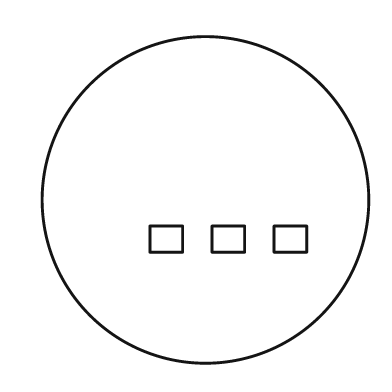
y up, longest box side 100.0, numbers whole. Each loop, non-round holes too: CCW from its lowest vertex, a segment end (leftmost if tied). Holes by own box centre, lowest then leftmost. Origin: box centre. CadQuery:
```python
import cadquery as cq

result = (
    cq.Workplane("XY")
    .moveTo(0.0, 0.0)
    .circle(50.0)
    .moveTo(-17.0, -16.0)
    .lineTo(-7.0, -16.0)
    .lineTo(-7.0, -8.0)
    .lineTo(-17.0, -8.0)
    .close()
    .moveTo(2.0, -16.0)
    .lineTo(12.0, -16.0)
    .lineTo(12.0, -8.0)
    .lineTo(2.0, -8.0)
    .close()
    .moveTo(21.0, -16.0)
    .lineTo(31.0, -16.0)
    .lineTo(31.0, -8.0)
    .lineTo(21.0, -8.0)
    .close()
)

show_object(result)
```